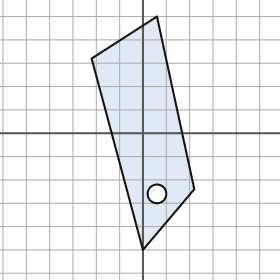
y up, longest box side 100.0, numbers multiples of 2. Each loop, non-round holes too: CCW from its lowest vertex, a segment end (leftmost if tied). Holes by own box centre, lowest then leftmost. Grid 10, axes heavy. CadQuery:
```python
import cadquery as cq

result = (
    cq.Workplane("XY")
    .moveTo(0.0, -50.0)
    .lineTo(22.0, -24.0)
    .lineTo(6.0, 50.0)
    .lineTo(-22.0, 32.0)
    .close()
    .moveTo(6.0, -26.0)
    .circle(4.0)
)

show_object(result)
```